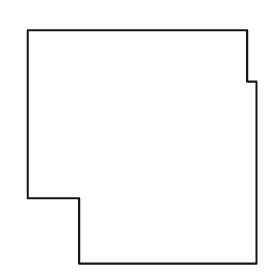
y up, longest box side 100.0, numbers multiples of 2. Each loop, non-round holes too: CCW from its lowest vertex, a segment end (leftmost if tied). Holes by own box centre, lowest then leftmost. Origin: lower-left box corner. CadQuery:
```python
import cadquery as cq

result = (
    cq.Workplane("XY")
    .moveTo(22.0, 0.0)
    .lineTo(98.0, 0.0)
    .lineTo(98.0, 78.0)
    .lineTo(94.0, 78.0)
    .lineTo(94.0, 100.0)
    .lineTo(0.0, 100.0)
    .lineTo(0.0, 28.0)
    .lineTo(22.0, 28.0)
    .close()
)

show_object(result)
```